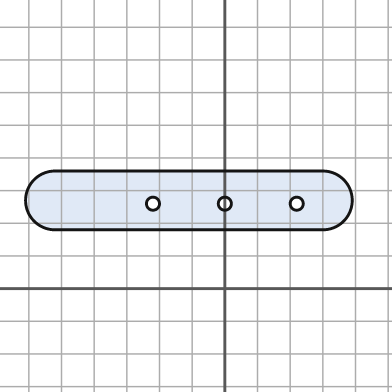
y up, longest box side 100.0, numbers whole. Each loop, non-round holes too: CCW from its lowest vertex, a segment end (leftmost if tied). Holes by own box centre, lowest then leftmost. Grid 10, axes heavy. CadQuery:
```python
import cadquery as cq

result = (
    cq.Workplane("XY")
    .moveTo(-52.0, 18.0)
    .lineTo(30.0, 18.0)
    .threePointArc((39.0, 27.0), (30.0, 36.0))
    .lineTo(-52.0, 36.0)
    .threePointArc((-61.0, 27.0), (-52.0, 18.0))
    .close()
    .moveTo(-22.0, 26.0)
    .circle(2.0)
    .moveTo(0.0, 26.0)
    .circle(2.0)
    .moveTo(22.0, 26.0)
    .circle(2.0)
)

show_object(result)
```